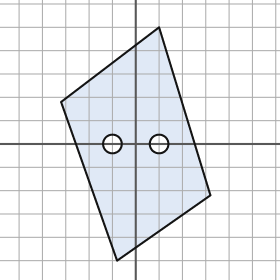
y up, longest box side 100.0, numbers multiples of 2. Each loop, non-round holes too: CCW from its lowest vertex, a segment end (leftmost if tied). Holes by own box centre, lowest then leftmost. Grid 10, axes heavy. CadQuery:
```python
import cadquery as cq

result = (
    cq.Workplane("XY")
    .moveTo(-8.0, -50.0)
    .lineTo(32.0, -22.0)
    .lineTo(10.0, 50.0)
    .lineTo(-32.0, 18.0)
    .close()
    .moveTo(-10.0, 0.0)
    .circle(4.0)
    .moveTo(10.0, 0.0)
    .circle(4.0)
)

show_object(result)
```